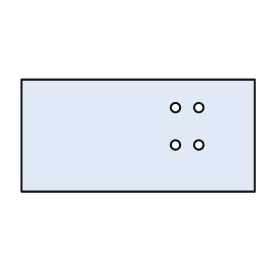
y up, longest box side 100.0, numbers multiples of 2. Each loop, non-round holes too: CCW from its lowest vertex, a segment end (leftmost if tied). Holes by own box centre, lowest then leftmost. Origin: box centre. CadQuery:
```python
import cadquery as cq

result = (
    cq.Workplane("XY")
    .moveTo(-50.0, -24.0)
    .lineTo(50.0, -24.0)
    .lineTo(50.0, 24.0)
    .lineTo(-50.0, 24.0)
    .close()
    .moveTo(16.0, -4.0)
    .circle(2.0)
    .moveTo(26.0, -4.0)
    .circle(2.0)
    .moveTo(16.0, 12.0)
    .circle(2.0)
    .moveTo(26.0, 12.0)
    .circle(2.0)
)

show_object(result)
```